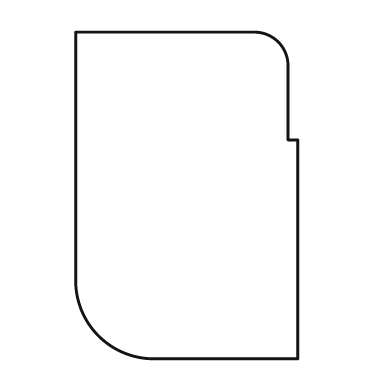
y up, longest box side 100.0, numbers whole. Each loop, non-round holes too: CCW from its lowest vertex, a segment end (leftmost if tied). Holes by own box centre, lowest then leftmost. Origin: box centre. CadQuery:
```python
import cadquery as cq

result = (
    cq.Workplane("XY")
    .moveTo(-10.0, -50.0)
    .lineTo(34.0, -50.0)
    .lineTo(34.0, 17.0)
    .lineTo(31.0, 17.0)
    .lineTo(31.0, 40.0)
    .threePointArc((28.0, 47.0), (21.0, 50.0))
    .lineTo(-34.0, 50.0)
    .lineTo(-34.0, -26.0)
    .threePointArc((-27.0, -43.0), (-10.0, -50.0))
    .close()
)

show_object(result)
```